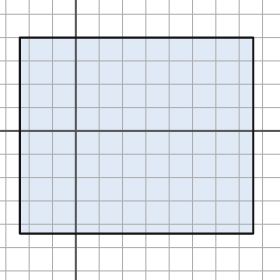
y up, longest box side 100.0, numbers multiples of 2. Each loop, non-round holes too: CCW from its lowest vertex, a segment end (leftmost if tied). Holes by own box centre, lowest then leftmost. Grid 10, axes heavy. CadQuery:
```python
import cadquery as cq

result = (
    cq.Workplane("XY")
    .moveTo(-24.0, -44.0)
    .lineTo(76.0, -44.0)
    .lineTo(76.0, 40.0)
    .lineTo(-24.0, 40.0)
    .close()
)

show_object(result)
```